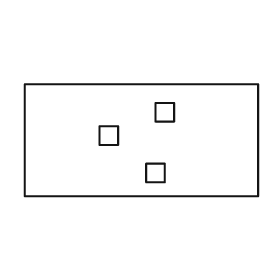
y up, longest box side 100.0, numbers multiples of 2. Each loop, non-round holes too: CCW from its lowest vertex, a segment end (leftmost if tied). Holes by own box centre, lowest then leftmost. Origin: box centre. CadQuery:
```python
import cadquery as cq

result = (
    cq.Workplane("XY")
    .moveTo(-50.0, -24.0)
    .lineTo(50.0, -24.0)
    .lineTo(50.0, 24.0)
    .lineTo(-50.0, 24.0)
    .close()
    .moveTo(2.0, -18.0)
    .lineTo(10.0, -18.0)
    .lineTo(10.0, -10.0)
    .lineTo(2.0, -10.0)
    .close()
    .moveTo(-18.0, -2.0)
    .lineTo(-10.0, -2.0)
    .lineTo(-10.0, 6.0)
    .lineTo(-18.0, 6.0)
    .close()
    .moveTo(6.0, 8.0)
    .lineTo(14.0, 8.0)
    .lineTo(14.0, 16.0)
    .lineTo(6.0, 16.0)
    .close()
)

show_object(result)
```